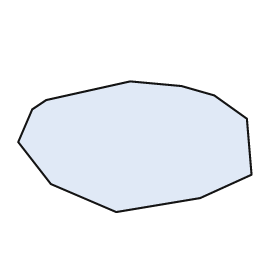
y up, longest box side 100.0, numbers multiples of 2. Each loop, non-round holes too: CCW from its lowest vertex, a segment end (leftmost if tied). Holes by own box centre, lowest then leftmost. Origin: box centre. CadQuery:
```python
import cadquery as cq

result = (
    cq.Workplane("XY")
    .moveTo(-8.0, -28.0)
    .lineTo(28.0, -22.0)
    .lineTo(50.0, -12.0)
    .lineTo(48.0, 12.0)
    .lineTo(34.0, 22.0)
    .lineTo(20.0, 26.0)
    .lineTo(-2.0, 28.0)
    .lineTo(-38.0, 20.0)
    .lineTo(-44.0, 16.0)
    .lineTo(-50.0, 2.0)
    .lineTo(-36.0, -16.0)
    .close()
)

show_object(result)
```